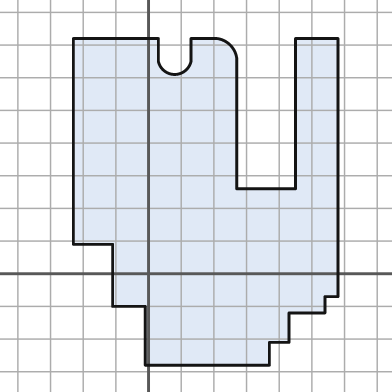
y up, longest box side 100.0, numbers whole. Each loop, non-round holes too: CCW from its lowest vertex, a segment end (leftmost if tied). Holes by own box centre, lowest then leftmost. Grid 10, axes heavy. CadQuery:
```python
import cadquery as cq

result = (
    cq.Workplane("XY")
    .moveTo(-1.0, -28.0)
    .lineTo(37.0, -28.0)
    .lineTo(37.0, -21.0)
    .lineTo(43.0, -21.0)
    .lineTo(43.0, -12.0)
    .lineTo(54.0, -12.0)
    .lineTo(54.0, -7.0)
    .lineTo(58.0, -7.0)
    .lineTo(58.0, 72.0)
    .lineTo(45.0, 72.0)
    .lineTo(45.0, 26.0)
    .lineTo(27.0, 26.0)
    .lineTo(27.0, 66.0)
    .threePointArc((25.0, 70.0), (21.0, 72.0))
    .lineTo(13.0, 72.0)
    .lineTo(13.0, 65.0)
    .threePointArc((8.0, 61.0), (3.0, 65.0))
    .lineTo(3.0, 72.0)
    .lineTo(-23.0, 72.0)
    .lineTo(-23.0, 9.0)
    .lineTo(-11.0, 9.0)
    .lineTo(-11.0, -10.0)
    .lineTo(-1.0, -10.0)
    .close()
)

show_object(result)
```